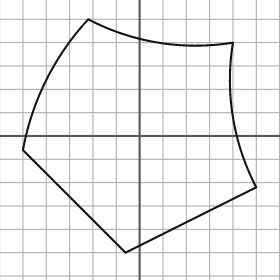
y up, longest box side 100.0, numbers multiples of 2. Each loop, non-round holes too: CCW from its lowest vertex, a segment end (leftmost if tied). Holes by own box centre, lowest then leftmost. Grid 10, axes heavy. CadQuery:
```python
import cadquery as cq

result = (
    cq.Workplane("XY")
    .moveTo(-6.0, -50.0)
    .lineTo(50.0, -22.0)
    .threePointArc((40.0, 8.0), (40.0, 40.0))
    .threePointArc((8.0, 40.0), (-22.0, 50.0))
    .threePointArc((-40.0, 24.0), (-50.0, -6.0))
    .close()
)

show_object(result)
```